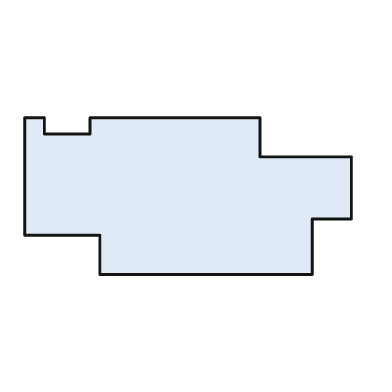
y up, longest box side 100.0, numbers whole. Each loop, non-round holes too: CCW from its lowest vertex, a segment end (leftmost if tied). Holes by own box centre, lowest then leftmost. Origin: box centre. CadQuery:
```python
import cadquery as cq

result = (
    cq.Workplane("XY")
    .moveTo(-27.0, -24.0)
    .lineTo(38.0, -24.0)
    .lineTo(38.0, -7.0)
    .lineTo(50.0, -7.0)
    .lineTo(50.0, 12.0)
    .lineTo(22.0, 12.0)
    .lineTo(22.0, 24.0)
    .lineTo(-30.0, 24.0)
    .lineTo(-30.0, 19.0)
    .lineTo(-44.0, 19.0)
    .lineTo(-44.0, 24.0)
    .lineTo(-50.0, 24.0)
    .lineTo(-50.0, -12.0)
    .lineTo(-27.0, -12.0)
    .close()
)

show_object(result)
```